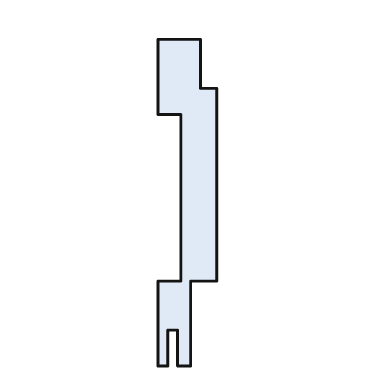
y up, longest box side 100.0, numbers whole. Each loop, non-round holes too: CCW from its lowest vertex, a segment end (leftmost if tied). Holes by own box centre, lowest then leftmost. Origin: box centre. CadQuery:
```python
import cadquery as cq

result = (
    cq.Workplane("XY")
    .moveTo(-9.0, -50.0)
    .lineTo(-6.0, -50.0)
    .lineTo(-6.0, -39.0)
    .lineTo(-3.0, -39.0)
    .lineTo(-3.0, -50.0)
    .lineTo(1.0, -50.0)
    .lineTo(1.0, -24.0)
    .lineTo(9.0, -24.0)
    .lineTo(9.0, 35.0)
    .lineTo(4.0, 35.0)
    .lineTo(4.0, 50.0)
    .lineTo(-9.0, 50.0)
    .lineTo(-9.0, 27.0)
    .lineTo(-2.0, 27.0)
    .lineTo(-2.0, -24.0)
    .lineTo(-9.0, -24.0)
    .close()
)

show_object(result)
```